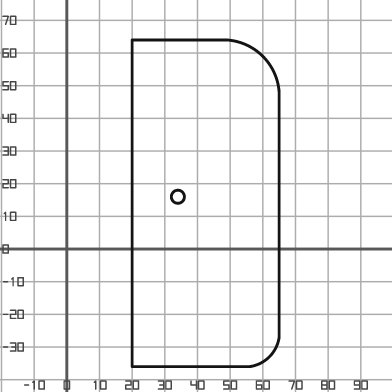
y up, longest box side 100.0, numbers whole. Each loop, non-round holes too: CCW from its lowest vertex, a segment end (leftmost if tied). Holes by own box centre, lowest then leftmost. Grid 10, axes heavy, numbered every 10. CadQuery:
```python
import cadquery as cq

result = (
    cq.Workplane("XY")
    .moveTo(20.0, -36.0)
    .lineTo(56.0, -36.0)
    .threePointArc((62.0, -33.0), (65.0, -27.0))
    .lineTo(65.0, 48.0)
    .threePointArc((60.0, 59.0), (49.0, 64.0))
    .lineTo(20.0, 64.0)
    .close()
    .moveTo(34.0, 16.0)
    .circle(2.0)
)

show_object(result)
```